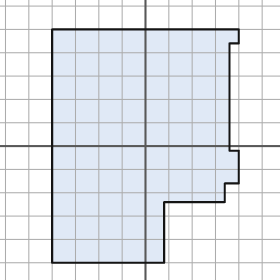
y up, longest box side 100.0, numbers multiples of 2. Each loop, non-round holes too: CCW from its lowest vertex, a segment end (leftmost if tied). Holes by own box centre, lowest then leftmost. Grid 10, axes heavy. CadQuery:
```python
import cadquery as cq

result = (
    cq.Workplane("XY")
    .moveTo(-40.0, -50.0)
    .lineTo(8.0, -50.0)
    .lineTo(8.0, -24.0)
    .lineTo(34.0, -24.0)
    .lineTo(34.0, -16.0)
    .lineTo(40.0, -16.0)
    .lineTo(40.0, -2.0)
    .lineTo(36.0, -2.0)
    .lineTo(36.0, 44.0)
    .lineTo(40.0, 44.0)
    .lineTo(40.0, 50.0)
    .lineTo(-40.0, 50.0)
    .close()
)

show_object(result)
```